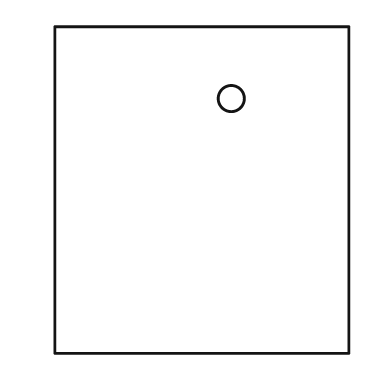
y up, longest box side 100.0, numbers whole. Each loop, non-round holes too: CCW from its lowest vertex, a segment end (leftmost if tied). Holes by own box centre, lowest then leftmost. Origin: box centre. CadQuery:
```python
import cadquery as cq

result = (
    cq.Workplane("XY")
    .moveTo(-45.0, -50.0)
    .lineTo(45.0, -50.0)
    .lineTo(45.0, 50.0)
    .lineTo(-45.0, 50.0)
    .close()
    .moveTo(9.0, 28.0)
    .circle(4.0)
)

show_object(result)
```